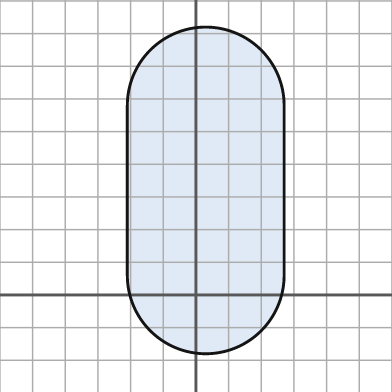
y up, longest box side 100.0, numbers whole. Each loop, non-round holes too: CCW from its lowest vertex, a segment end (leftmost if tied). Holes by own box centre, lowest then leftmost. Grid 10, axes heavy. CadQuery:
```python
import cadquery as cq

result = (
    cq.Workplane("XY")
    .moveTo(-21.0, 6.0)
    .threePointArc((3.0, -18.0), (27.0, 6.0))
    .lineTo(27.0, 58.0)
    .threePointArc((3.0, 82.0), (-21.0, 58.0))
    .close()
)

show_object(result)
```